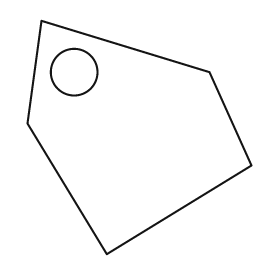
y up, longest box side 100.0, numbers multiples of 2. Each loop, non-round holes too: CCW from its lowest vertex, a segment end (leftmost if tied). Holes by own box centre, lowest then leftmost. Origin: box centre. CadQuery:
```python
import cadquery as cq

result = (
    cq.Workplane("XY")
    .moveTo(-14.0, -50.0)
    .lineTo(48.0, -12.0)
    .lineTo(30.0, 28.0)
    .lineTo(-42.0, 50.0)
    .lineTo(-48.0, 6.0)
    .close()
    .moveTo(-28.0, 28.0)
    .circle(10.0)
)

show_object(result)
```